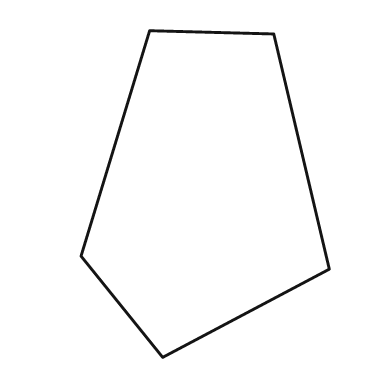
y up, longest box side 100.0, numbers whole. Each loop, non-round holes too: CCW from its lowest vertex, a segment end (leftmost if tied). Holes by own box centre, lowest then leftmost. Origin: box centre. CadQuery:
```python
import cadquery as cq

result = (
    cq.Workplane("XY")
    .moveTo(-13.0, -50.0)
    .lineTo(38.0, -23.0)
    .lineTo(21.0, 49.0)
    .lineTo(-17.0, 50.0)
    .lineTo(-38.0, -19.0)
    .close()
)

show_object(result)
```